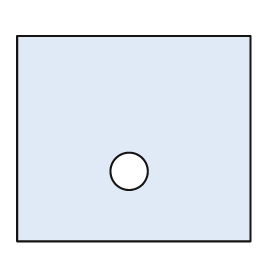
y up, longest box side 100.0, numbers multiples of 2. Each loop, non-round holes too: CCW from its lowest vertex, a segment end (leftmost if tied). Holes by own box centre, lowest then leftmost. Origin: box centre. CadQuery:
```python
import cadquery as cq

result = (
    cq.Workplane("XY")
    .moveTo(-50.0, -44.0)
    .lineTo(50.0, -44.0)
    .lineTo(50.0, 44.0)
    .lineTo(-50.0, 44.0)
    .close()
    .moveTo(-2.0, -14.0)
    .circle(8.0)
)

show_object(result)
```